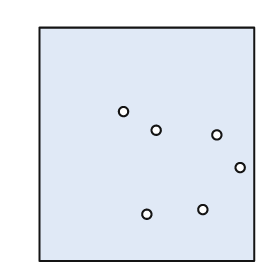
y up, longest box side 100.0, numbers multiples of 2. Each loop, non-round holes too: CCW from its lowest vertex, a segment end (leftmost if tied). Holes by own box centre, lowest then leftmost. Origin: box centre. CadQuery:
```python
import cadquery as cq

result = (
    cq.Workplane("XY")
    .moveTo(-46.0, -50.0)
    .lineTo(46.0, -50.0)
    .lineTo(46.0, 50.0)
    .lineTo(-46.0, 50.0)
    .close()
    .moveTo(0.0, -30.0)
    .circle(2.0)
    .moveTo(24.0, -28.0)
    .circle(2.0)
    .moveTo(40.0, -10.0)
    .circle(2.0)
    .moveTo(30.0, 4.0)
    .circle(2.0)
    .moveTo(4.0, 6.0)
    .circle(2.0)
    .moveTo(-10.0, 14.0)
    .circle(2.0)
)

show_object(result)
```